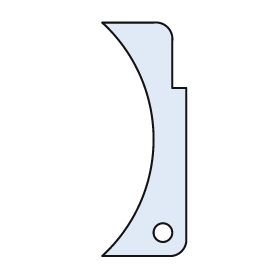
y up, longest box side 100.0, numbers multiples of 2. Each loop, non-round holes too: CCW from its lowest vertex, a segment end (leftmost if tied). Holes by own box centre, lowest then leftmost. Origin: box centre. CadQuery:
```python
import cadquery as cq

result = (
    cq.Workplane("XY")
    .moveTo(-18.0, -50.0)
    .lineTo(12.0, -50.0)
    .threePointArc((16.0, -48.0), (18.0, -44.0))
    .lineTo(18.0, 22.0)
    .lineTo(12.0, 22.0)
    .lineTo(12.0, 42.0)
    .threePointArc((10.0, 48.0), (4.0, 50.0))
    .lineTo(-18.0, 50.0)
    .threePointArc((4.0, 0.0), (-18.0, -50.0))
    .close()
    .moveTo(8.0, -40.0)
    .circle(4.0)
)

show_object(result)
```